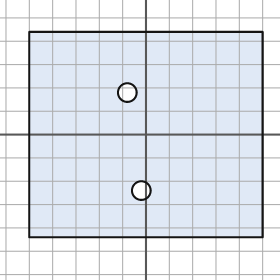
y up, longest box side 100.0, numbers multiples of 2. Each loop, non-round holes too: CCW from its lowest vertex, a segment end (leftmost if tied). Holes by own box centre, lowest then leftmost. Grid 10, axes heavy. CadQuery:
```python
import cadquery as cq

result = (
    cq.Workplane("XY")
    .moveTo(-50.0, -44.0)
    .lineTo(50.0, -44.0)
    .lineTo(50.0, 44.0)
    .lineTo(-50.0, 44.0)
    .close()
    .moveTo(-2.0, -24.0)
    .circle(4.0)
    .moveTo(-8.0, 18.0)
    .circle(4.0)
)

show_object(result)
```